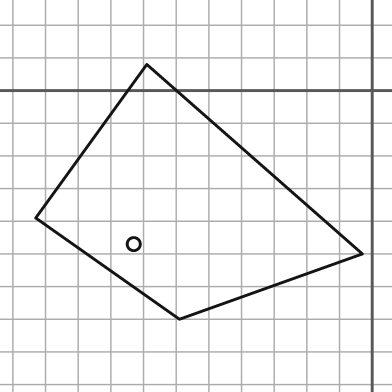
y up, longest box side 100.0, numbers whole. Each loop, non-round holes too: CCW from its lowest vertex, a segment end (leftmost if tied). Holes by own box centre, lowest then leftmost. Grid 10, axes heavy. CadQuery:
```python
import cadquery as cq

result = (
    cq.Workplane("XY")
    .moveTo(-59.0, -70.0)
    .lineTo(-3.0, -50.0)
    .lineTo(-69.0, 8.0)
    .lineTo(-103.0, -39.0)
    .close()
    .moveTo(-73.0, -47.0)
    .circle(2.0)
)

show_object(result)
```